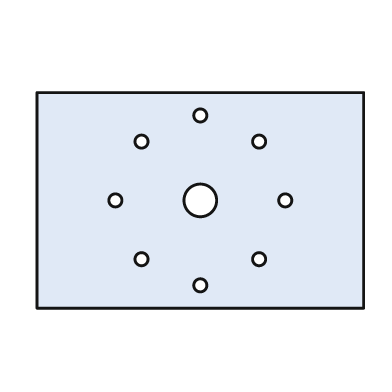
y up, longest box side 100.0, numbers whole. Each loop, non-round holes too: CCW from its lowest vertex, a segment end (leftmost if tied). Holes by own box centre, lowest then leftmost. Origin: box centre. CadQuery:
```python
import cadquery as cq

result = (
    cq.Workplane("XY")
    .moveTo(-50.0, -33.0)
    .lineTo(50.0, -33.0)
    .lineTo(50.0, 33.0)
    .lineTo(-50.0, 33.0)
    .close()
    .moveTo(0.0, -26.0)
    .circle(2.0)
    .moveTo(-18.0, -18.0)
    .circle(2.0)
    .moveTo(18.0, -18.0)
    .circle(2.0)
    .moveTo(-26.0, 0.0)
    .circle(2.0)
    .moveTo(0.0, 0.0)
    .circle(5.0)
    .moveTo(26.0, 0.0)
    .circle(2.0)
    .moveTo(-18.0, 18.0)
    .circle(2.0)
    .moveTo(18.0, 18.0)
    .circle(2.0)
    .moveTo(0.0, 26.0)
    .circle(2.0)
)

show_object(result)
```